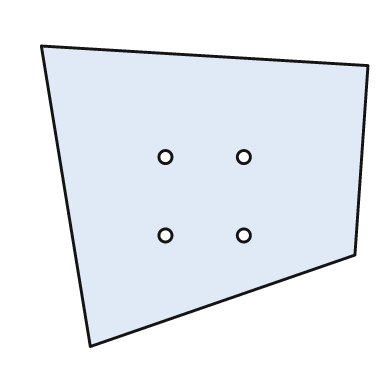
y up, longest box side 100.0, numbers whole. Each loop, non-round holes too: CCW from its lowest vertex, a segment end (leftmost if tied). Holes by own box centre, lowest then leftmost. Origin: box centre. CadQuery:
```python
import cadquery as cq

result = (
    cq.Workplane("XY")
    .moveTo(-35.0, -46.0)
    .lineTo(46.0, -18.0)
    .lineTo(50.0, 40.0)
    .lineTo(-50.0, 46.0)
    .close()
    .moveTo(-12.0, -12.0)
    .circle(2.0)
    .moveTo(12.0, -12.0)
    .circle(2.0)
    .moveTo(-12.0, 12.0)
    .circle(2.0)
    .moveTo(12.0, 12.0)
    .circle(2.0)
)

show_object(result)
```